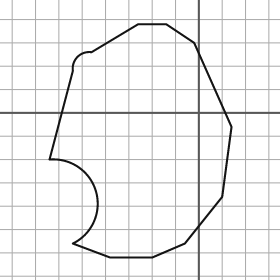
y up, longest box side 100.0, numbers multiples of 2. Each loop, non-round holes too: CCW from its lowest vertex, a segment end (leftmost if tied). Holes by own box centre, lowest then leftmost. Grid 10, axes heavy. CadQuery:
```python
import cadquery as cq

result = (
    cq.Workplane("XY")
    .moveTo(-38.0, -62.0)
    .lineTo(-20.0, -62.0)
    .lineTo(-6.0, -56.0)
    .lineTo(10.0, -36.0)
    .lineTo(14.0, -6.0)
    .lineTo(-2.0, 30.0)
    .lineTo(-14.0, 38.0)
    .lineTo(-26.0, 38.0)
    .lineTo(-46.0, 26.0)
    .threePointArc((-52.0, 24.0), (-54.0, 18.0))
    .lineTo(-64.0, -20.0)
    .threePointArc((-44.0, -34.0), (-54.0, -56.0))
    .close()
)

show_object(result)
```